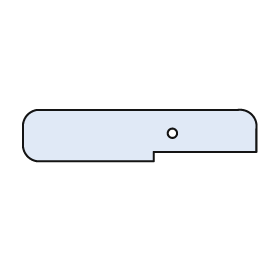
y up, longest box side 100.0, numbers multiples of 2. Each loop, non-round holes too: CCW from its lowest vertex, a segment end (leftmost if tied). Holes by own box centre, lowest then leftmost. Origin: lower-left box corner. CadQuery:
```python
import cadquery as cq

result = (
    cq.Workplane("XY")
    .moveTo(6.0, 0.0)
    .lineTo(56.0, 0.0)
    .lineTo(56.0, 4.0)
    .lineTo(100.0, 4.0)
    .lineTo(100.0, 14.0)
    .threePointArc((98.0, 20.0), (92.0, 22.0))
    .lineTo(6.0, 22.0)
    .threePointArc((2.0, 20.0), (0.0, 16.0))
    .lineTo(0.0, 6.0)
    .threePointArc((2.0, 2.0), (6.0, 0.0))
    .close()
    .moveTo(64.0, 12.0)
    .circle(2.0)
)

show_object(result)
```